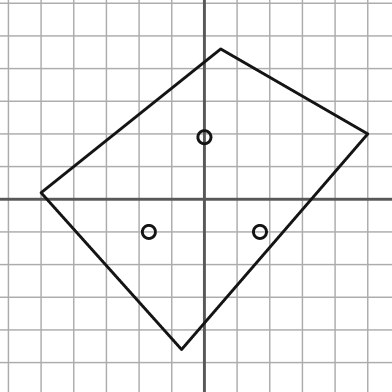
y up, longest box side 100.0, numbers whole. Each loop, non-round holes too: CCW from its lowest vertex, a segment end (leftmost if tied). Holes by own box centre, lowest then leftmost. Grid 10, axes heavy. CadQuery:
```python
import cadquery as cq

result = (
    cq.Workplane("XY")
    .moveTo(-7.0, -46.0)
    .lineTo(50.0, 20.0)
    .lineTo(5.0, 46.0)
    .lineTo(-50.0, 2.0)
    .close()
    .moveTo(-17.0, -10.0)
    .circle(2.0)
    .moveTo(17.0, -10.0)
    .circle(2.0)
    .moveTo(0.0, 19.0)
    .circle(2.0)
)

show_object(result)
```